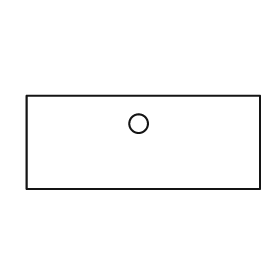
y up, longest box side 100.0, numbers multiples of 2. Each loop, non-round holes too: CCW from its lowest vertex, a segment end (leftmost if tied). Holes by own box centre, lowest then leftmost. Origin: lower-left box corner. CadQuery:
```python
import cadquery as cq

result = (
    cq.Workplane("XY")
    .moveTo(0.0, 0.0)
    .lineTo(100.0, 0.0)
    .lineTo(100.0, 40.0)
    .lineTo(0.0, 40.0)
    .close()
    .moveTo(48.0, 28.0)
    .circle(4.0)
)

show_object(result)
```